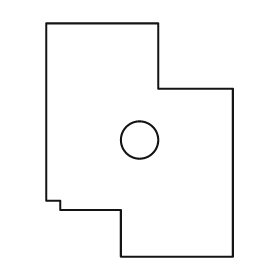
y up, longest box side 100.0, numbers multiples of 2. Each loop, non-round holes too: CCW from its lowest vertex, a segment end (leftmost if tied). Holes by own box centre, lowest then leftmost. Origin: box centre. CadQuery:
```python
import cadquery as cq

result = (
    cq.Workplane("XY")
    .moveTo(-8.0, -50.0)
    .lineTo(40.0, -50.0)
    .lineTo(40.0, 22.0)
    .lineTo(8.0, 22.0)
    .lineTo(8.0, 50.0)
    .lineTo(-40.0, 50.0)
    .lineTo(-40.0, -26.0)
    .lineTo(-34.0, -26.0)
    .lineTo(-34.0, -30.0)
    .lineTo(-8.0, -30.0)
    .close()
    .moveTo(0.0, 0.0)
    .circle(8.0)
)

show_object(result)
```